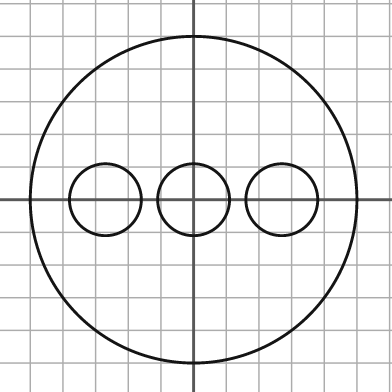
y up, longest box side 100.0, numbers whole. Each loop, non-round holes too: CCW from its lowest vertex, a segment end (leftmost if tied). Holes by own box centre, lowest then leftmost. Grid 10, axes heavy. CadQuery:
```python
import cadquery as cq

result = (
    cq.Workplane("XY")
    .moveTo(0.0, 0.0)
    .circle(50.0)
    .moveTo(-27.0, 0.0)
    .circle(11.0)
    .moveTo(0.0, 0.0)
    .circle(11.0)
    .moveTo(27.0, 0.0)
    .circle(11.0)
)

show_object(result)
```